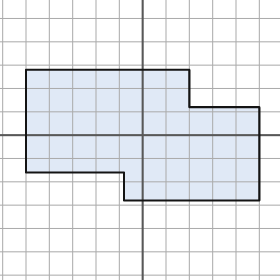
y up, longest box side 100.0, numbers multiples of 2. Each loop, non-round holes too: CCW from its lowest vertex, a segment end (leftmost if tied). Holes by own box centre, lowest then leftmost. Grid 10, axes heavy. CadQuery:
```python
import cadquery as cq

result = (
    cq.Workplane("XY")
    .moveTo(-8.0, -28.0)
    .lineTo(50.0, -28.0)
    .lineTo(50.0, 12.0)
    .lineTo(20.0, 12.0)
    .lineTo(20.0, 28.0)
    .lineTo(-50.0, 28.0)
    .lineTo(-50.0, -16.0)
    .lineTo(-8.0, -16.0)
    .close()
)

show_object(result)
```